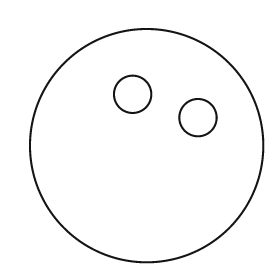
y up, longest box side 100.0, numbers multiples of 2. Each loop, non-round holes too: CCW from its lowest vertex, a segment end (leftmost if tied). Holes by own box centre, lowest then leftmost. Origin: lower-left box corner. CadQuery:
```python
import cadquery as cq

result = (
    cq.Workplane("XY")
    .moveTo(50.0, 50.0)
    .circle(50.0)
    .moveTo(72.0, 62.0)
    .circle(8.0)
    .moveTo(44.0, 72.0)
    .circle(8.0)
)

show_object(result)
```